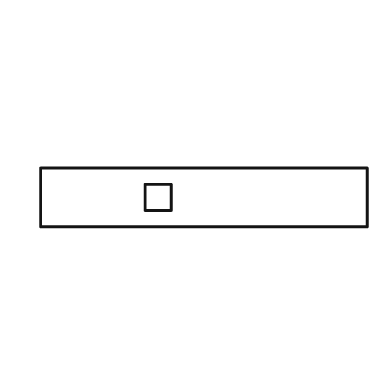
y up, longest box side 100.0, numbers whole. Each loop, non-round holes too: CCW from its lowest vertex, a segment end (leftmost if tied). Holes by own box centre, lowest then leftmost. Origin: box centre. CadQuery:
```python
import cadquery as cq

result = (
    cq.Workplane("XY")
    .moveTo(-50.0, -9.0)
    .lineTo(50.0, -9.0)
    .lineTo(50.0, 9.0)
    .lineTo(-50.0, 9.0)
    .close()
    .moveTo(-18.0, -4.0)
    .lineTo(-10.0, -4.0)
    .lineTo(-10.0, 4.0)
    .lineTo(-18.0, 4.0)
    .close()
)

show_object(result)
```